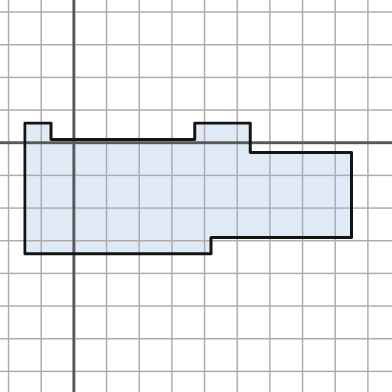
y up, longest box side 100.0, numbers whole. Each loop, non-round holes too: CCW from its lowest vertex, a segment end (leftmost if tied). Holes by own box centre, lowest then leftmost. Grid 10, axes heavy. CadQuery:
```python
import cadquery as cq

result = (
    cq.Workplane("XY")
    .moveTo(-15.0, -34.0)
    .lineTo(42.0, -34.0)
    .lineTo(42.0, -29.0)
    .lineTo(85.0, -29.0)
    .lineTo(85.0, -3.0)
    .lineTo(54.0, -3.0)
    .lineTo(54.0, 6.0)
    .lineTo(37.0, 6.0)
    .lineTo(37.0, 1.0)
    .lineTo(-7.0, 1.0)
    .lineTo(-7.0, 6.0)
    .lineTo(-15.0, 6.0)
    .close()
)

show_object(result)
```